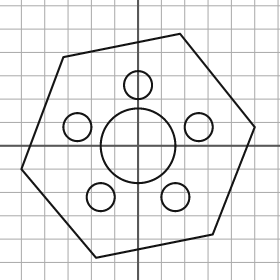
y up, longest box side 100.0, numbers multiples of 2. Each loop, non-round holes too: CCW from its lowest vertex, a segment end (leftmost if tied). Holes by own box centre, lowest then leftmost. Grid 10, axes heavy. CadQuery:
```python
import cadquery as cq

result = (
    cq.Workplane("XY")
    .moveTo(-18.0, -48.0)
    .lineTo(32.0, -38.0)
    .lineTo(50.0, 8.0)
    .lineTo(18.0, 48.0)
    .lineTo(-32.0, 38.0)
    .lineTo(-50.0, -10.0)
    .close()
    .moveTo(-16.0, -22.0)
    .circle(6.0)
    .moveTo(16.0, -22.0)
    .circle(6.0)
    .moveTo(0.0, 0.0)
    .circle(16.0)
    .moveTo(-26.0, 8.0)
    .circle(6.0)
    .moveTo(26.0, 8.0)
    .circle(6.0)
    .moveTo(0.0, 26.0)
    .circle(6.0)
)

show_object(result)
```